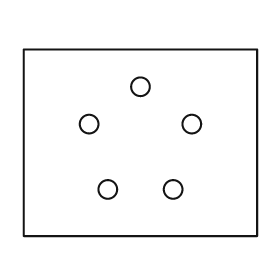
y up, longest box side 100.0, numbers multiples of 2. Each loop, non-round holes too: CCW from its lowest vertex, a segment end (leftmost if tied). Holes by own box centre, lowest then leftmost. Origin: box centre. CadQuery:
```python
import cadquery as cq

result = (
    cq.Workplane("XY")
    .moveTo(-50.0, -40.0)
    .lineTo(50.0, -40.0)
    .lineTo(50.0, 40.0)
    .lineTo(-50.0, 40.0)
    .close()
    .moveTo(-14.0, -20.0)
    .circle(4.0)
    .moveTo(14.0, -20.0)
    .circle(4.0)
    .moveTo(-22.0, 8.0)
    .circle(4.0)
    .moveTo(22.0, 8.0)
    .circle(4.0)
    .moveTo(0.0, 24.0)
    .circle(4.0)
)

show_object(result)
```